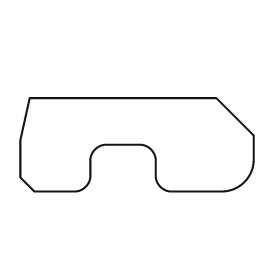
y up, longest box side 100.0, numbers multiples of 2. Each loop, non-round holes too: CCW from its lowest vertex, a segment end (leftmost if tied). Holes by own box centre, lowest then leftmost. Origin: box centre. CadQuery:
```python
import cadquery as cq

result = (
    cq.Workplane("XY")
    .moveTo(-44.0, -20.0)
    .lineTo(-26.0, -20.0)
    .threePointArc((-22.0, -18.0), (-20.0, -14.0))
    .lineTo(-20.0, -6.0)
    .threePointArc((-18.0, -2.0), (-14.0, 0.0))
    .lineTo(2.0, 0.0)
    .threePointArc((6.0, -2.0), (8.0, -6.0))
    .lineTo(8.0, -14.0)
    .threePointArc((10.0, -18.0), (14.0, -20.0))
    .lineTo(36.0, -20.0)
    .threePointArc((46.0, -16.0), (50.0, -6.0))
    .lineTo(50.0, 4.0)
    .lineTo(34.0, 20.0)
    .lineTo(-46.0, 20.0)
    .lineTo(-50.0, 2.0)
    .lineTo(-50.0, -14.0)
    .close()
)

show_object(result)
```